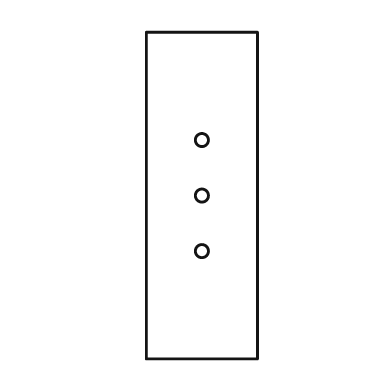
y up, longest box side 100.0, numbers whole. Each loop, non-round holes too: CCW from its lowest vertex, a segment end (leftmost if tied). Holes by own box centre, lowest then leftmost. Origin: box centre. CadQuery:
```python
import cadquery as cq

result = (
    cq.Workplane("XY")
    .moveTo(-17.0, -50.0)
    .lineTo(17.0, -50.0)
    .lineTo(17.0, 50.0)
    .lineTo(-17.0, 50.0)
    .close()
    .moveTo(0.0, -17.0)
    .circle(2.0)
    .moveTo(0.0, 0.0)
    .circle(2.0)
    .moveTo(0.0, 17.0)
    .circle(2.0)
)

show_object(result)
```